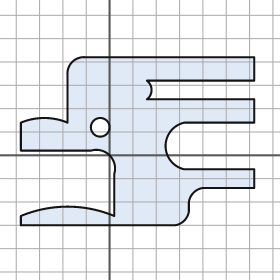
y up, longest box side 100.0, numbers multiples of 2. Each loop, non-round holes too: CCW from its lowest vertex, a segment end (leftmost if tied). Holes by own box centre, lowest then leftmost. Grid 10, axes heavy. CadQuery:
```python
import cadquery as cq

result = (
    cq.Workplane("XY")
    .moveTo(-38.0, -30.0)
    .lineTo(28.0, -30.0)
    .threePointArc((32.0, -28.0), (34.0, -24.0))
    .lineTo(34.0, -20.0)
    .threePointArc((36.0, -16.0), (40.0, -14.0))
    .lineTo(62.0, -14.0)
    .lineTo(62.0, -6.0)
    .lineTo(32.0, -6.0)
    .threePointArc((24.0, 4.0), (32.0, 14.0))
    .lineTo(62.0, 14.0)
    .lineTo(62.0, 24.0)
    .lineTo(16.0, 24.0)
    .threePointArc((18.0, 28.0), (16.0, 32.0))
    .lineTo(62.0, 32.0)
    .lineTo(62.0, 42.0)
    .lineTo(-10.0, 42.0)
    .threePointArc((-16.0, 40.0), (-18.0, 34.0))
    .lineTo(-18.0, 14.0)
    .threePointArc((-28.0, 16.0), (-38.0, 14.0))
    .lineTo(-38.0, 2.0)
    .lineTo(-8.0, 2.0)
    .threePointArc((0.0, 0.0), (2.0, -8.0))
    .lineTo(2.0, -26.0)
    .threePointArc((-18.0, -22.0), (-38.0, -26.0))
    .close()
    .moveTo(-4.0, 12.0)
    .circle(4.0)
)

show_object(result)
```